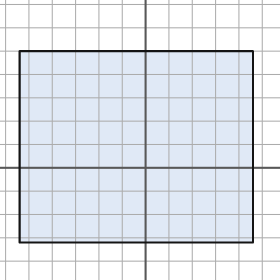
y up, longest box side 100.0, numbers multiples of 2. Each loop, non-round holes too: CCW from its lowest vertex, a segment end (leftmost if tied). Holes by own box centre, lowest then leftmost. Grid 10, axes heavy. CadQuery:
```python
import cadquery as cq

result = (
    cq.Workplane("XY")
    .moveTo(-54.0, -32.0)
    .lineTo(46.0, -32.0)
    .lineTo(46.0, 50.0)
    .lineTo(-54.0, 50.0)
    .close()
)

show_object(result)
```